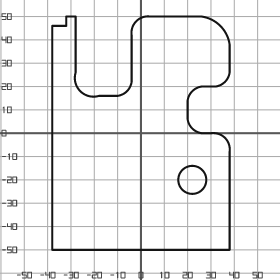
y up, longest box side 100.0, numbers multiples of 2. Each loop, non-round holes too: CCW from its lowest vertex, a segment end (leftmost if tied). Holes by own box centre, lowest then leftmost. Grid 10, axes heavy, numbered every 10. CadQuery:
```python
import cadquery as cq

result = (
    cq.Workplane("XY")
    .moveTo(-38.0, -50.0)
    .lineTo(38.0, -50.0)
    .lineTo(38.0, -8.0)
    .threePointArc((36.0, -2.0), (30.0, 0.0))
    .lineTo(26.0, 0.0)
    .threePointArc((22.0, 2.0), (20.0, 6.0))
    .lineTo(20.0, 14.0)
    .threePointArc((22.0, 18.0), (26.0, 20.0))
    .lineTo(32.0, 20.0)
    .threePointArc((36.0, 22.0), (38.0, 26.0))
    .lineTo(38.0, 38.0)
    .threePointArc((34.0, 46.0), (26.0, 50.0))
    .lineTo(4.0, 50.0)
    .threePointArc((-2.0, 48.0), (-4.0, 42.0))
    .lineTo(-4.0, 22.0)
    .threePointArc((-6.0, 18.0), (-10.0, 16.0))
    .lineTo(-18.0, 16.0)
    .threePointArc((-26.0, 18.0), (-28.0, 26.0))
    .lineTo(-28.0, 50.0)
    .lineTo(-32.0, 50.0)
    .lineTo(-32.0, 46.0)
    .lineTo(-38.0, 46.0)
    .close()
    .moveTo(22.0, -20.0)
    .circle(6.0)
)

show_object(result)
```